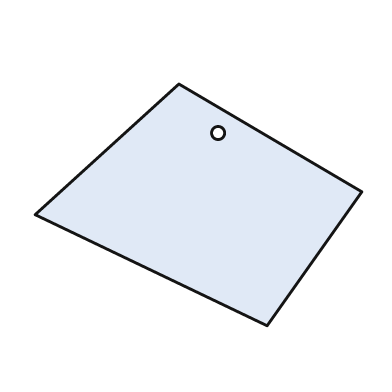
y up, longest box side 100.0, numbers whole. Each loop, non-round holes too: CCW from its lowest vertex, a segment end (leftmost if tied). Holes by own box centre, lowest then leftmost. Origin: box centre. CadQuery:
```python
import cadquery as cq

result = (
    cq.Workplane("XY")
    .moveTo(21.0, -37.0)
    .lineTo(50.0, 4.0)
    .lineTo(-6.0, 37.0)
    .lineTo(-50.0, -3.0)
    .close()
    .moveTo(6.0, 22.0)
    .circle(2.0)
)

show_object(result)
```